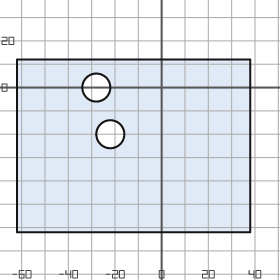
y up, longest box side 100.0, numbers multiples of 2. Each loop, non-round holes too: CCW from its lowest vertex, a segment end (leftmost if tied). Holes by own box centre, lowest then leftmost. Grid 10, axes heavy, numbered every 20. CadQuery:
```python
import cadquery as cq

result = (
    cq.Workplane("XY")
    .moveTo(-62.0, -62.0)
    .lineTo(38.0, -62.0)
    .lineTo(38.0, 12.0)
    .lineTo(-62.0, 12.0)
    .close()
    .moveTo(-22.0, -20.0)
    .circle(6.0)
    .moveTo(-28.0, 0.0)
    .circle(6.0)
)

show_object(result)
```